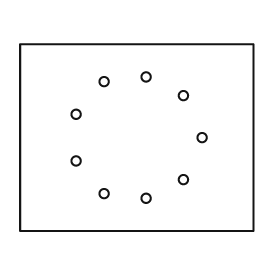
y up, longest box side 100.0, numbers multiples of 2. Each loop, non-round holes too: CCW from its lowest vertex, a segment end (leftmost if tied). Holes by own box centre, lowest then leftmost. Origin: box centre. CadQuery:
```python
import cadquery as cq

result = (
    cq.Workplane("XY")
    .moveTo(-50.0, -40.0)
    .lineTo(50.0, -40.0)
    .lineTo(50.0, 40.0)
    .lineTo(-50.0, 40.0)
    .close()
    .moveTo(4.0, -26.0)
    .circle(2.0)
    .moveTo(-14.0, -24.0)
    .circle(2.0)
    .moveTo(20.0, -18.0)
    .circle(2.0)
    .moveTo(-26.0, -10.0)
    .circle(2.0)
    .moveTo(28.0, 0.0)
    .circle(2.0)
    .moveTo(-26.0, 10.0)
    .circle(2.0)
    .moveTo(20.0, 18.0)
    .circle(2.0)
    .moveTo(-14.0, 24.0)
    .circle(2.0)
    .moveTo(4.0, 26.0)
    .circle(2.0)
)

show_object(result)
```